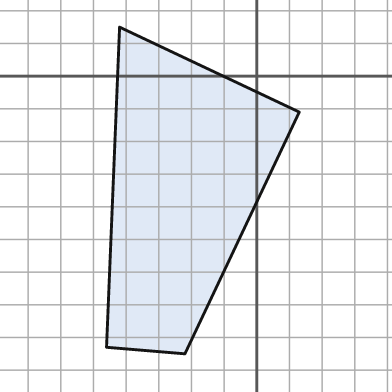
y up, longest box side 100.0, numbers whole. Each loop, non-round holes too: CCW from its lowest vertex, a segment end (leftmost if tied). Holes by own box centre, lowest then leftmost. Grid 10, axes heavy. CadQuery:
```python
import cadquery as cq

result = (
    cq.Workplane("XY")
    .moveTo(-22.0, -85.0)
    .lineTo(13.0, -11.0)
    .lineTo(-42.0, 15.0)
    .lineTo(-46.0, -83.0)
    .close()
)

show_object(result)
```